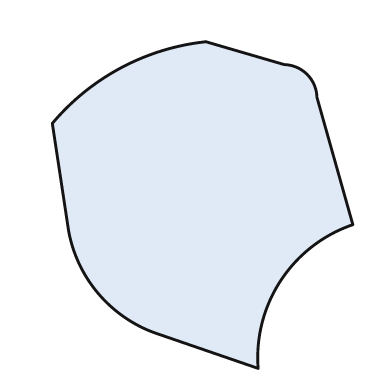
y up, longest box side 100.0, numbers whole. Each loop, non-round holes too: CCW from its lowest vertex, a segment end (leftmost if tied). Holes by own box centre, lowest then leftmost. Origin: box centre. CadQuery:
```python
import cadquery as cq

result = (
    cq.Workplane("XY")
    .moveTo(17.0, -50.0)
    .threePointArc((24.0, -23.0), (46.0, -6.0))
    .lineTo(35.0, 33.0)
    .threePointArc((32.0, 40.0), (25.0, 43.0))
    .lineTo(1.0, 50.0)
    .threePointArc((-25.0, 42.0), (-46.0, 25.0))
    .lineTo(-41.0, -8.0)
    .threePointArc((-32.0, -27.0), (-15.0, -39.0))
    .close()
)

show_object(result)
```